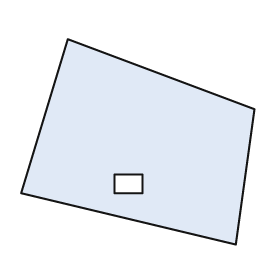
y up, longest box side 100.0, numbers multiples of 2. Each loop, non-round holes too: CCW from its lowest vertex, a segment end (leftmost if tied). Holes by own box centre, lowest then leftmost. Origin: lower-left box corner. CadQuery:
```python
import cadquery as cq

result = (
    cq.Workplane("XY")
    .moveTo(92.0, 0.0)
    .lineTo(100.0, 58.0)
    .lineTo(20.0, 88.0)
    .lineTo(0.0, 22.0)
    .close()
    .moveTo(40.0, 22.0)
    .lineTo(52.0, 22.0)
    .lineTo(52.0, 30.0)
    .lineTo(40.0, 30.0)
    .close()
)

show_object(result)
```